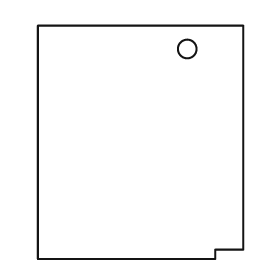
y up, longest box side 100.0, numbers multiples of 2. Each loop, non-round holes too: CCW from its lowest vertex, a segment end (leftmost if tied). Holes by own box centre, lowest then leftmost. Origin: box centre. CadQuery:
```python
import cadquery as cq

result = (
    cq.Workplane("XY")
    .moveTo(-44.0, -50.0)
    .lineTo(32.0, -50.0)
    .lineTo(32.0, -46.0)
    .lineTo(44.0, -46.0)
    .lineTo(44.0, 50.0)
    .lineTo(-44.0, 50.0)
    .close()
    .moveTo(20.0, 40.0)
    .circle(4.0)
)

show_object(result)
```